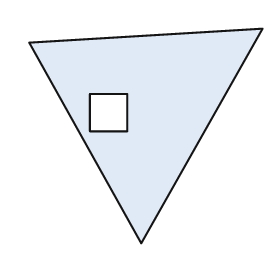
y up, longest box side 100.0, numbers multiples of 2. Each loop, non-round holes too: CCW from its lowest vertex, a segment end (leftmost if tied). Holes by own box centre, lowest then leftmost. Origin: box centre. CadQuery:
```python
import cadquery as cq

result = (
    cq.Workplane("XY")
    .moveTo(-2.0, -46.0)
    .lineTo(50.0, 46.0)
    .lineTo(-50.0, 40.0)
    .close()
    .moveTo(-24.0, 2.0)
    .lineTo(-8.0, 2.0)
    .lineTo(-8.0, 18.0)
    .lineTo(-24.0, 18.0)
    .close()
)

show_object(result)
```